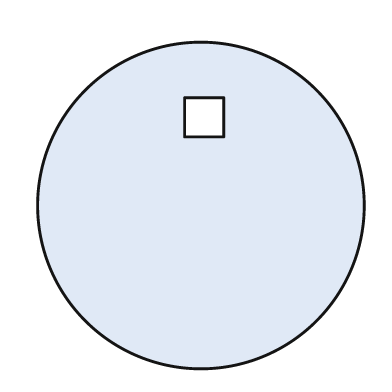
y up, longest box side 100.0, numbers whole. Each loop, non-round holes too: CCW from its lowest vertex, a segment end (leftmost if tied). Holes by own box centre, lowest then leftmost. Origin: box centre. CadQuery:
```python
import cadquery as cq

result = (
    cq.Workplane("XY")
    .moveTo(0.0, 0.0)
    .circle(50.0)
    .moveTo(-5.0, 21.0)
    .lineTo(7.0, 21.0)
    .lineTo(7.0, 33.0)
    .lineTo(-5.0, 33.0)
    .close()
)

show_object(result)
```